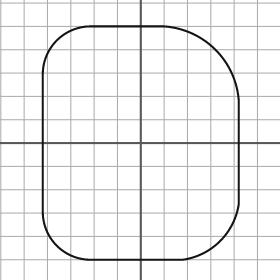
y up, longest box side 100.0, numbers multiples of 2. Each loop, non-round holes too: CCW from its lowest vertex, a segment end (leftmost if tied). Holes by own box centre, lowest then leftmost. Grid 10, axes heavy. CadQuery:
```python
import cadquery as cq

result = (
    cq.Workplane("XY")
    .moveTo(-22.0, -50.0)
    .lineTo(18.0, -50.0)
    .threePointArc((34.0, -42.0), (42.0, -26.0))
    .lineTo(42.0, 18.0)
    .threePointArc((32.0, 40.0), (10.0, 50.0))
    .lineTo(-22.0, 50.0)
    .threePointArc((-36.0, 44.0), (-42.0, 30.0))
    .lineTo(-42.0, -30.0)
    .threePointArc((-36.0, -44.0), (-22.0, -50.0))
    .close()
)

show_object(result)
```